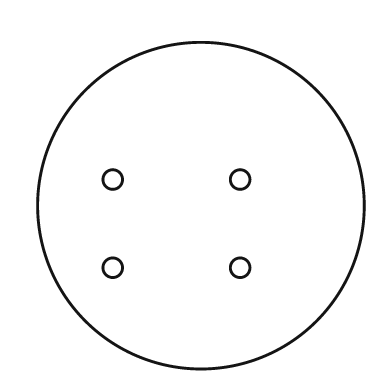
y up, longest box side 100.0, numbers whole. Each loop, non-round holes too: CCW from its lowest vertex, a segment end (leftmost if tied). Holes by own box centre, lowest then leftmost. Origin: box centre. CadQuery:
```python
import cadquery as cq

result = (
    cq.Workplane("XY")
    .moveTo(0.0, 0.0)
    .circle(50.0)
    .moveTo(-27.0, -19.0)
    .circle(3.0)
    .moveTo(12.0, -19.0)
    .circle(3.0)
    .moveTo(-27.0, 8.0)
    .circle(3.0)
    .moveTo(12.0, 8.0)
    .circle(3.0)
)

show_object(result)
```